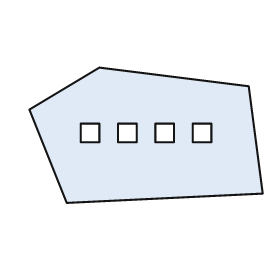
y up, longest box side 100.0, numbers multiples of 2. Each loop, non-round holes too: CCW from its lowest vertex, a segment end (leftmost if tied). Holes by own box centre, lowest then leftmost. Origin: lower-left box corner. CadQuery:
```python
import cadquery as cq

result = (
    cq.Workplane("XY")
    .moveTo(16.0, 0.0)
    .lineTo(100.0, 4.0)
    .lineTo(94.0, 50.0)
    .lineTo(30.0, 58.0)
    .lineTo(0.0, 40.0)
    .close()
    .moveTo(22.0, 26.0)
    .lineTo(30.0, 26.0)
    .lineTo(30.0, 34.0)
    .lineTo(22.0, 34.0)
    .close()
    .moveTo(38.0, 26.0)
    .lineTo(46.0, 26.0)
    .lineTo(46.0, 34.0)
    .lineTo(38.0, 34.0)
    .close()
    .moveTo(54.0, 26.0)
    .lineTo(62.0, 26.0)
    .lineTo(62.0, 34.0)
    .lineTo(54.0, 34.0)
    .close()
    .moveTo(70.0, 26.0)
    .lineTo(78.0, 26.0)
    .lineTo(78.0, 34.0)
    .lineTo(70.0, 34.0)
    .close()
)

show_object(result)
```